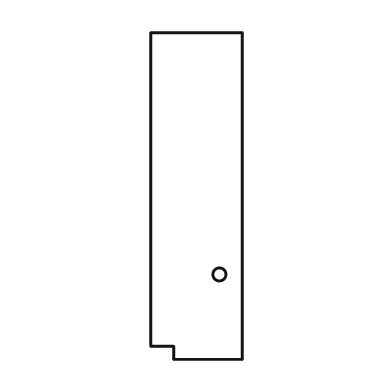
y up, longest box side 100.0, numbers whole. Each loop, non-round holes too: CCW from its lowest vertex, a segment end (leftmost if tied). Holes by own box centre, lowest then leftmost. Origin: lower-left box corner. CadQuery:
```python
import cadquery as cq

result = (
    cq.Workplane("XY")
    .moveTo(7.0, 0.0)
    .lineTo(28.0, 0.0)
    .lineTo(28.0, 100.0)
    .lineTo(0.0, 100.0)
    .lineTo(0.0, 4.0)
    .lineTo(7.0, 4.0)
    .close()
    .moveTo(21.0, 26.0)
    .circle(2.0)
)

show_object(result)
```